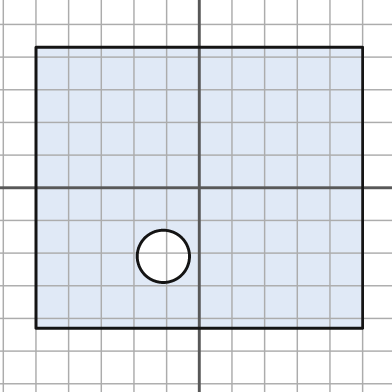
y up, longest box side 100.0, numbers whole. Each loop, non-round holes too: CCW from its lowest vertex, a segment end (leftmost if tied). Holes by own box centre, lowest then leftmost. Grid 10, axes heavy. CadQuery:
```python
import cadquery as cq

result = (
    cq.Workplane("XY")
    .moveTo(-50.0, -43.0)
    .lineTo(50.0, -43.0)
    .lineTo(50.0, 43.0)
    .lineTo(-50.0, 43.0)
    .close()
    .moveTo(-11.0, -21.0)
    .circle(8.0)
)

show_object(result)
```